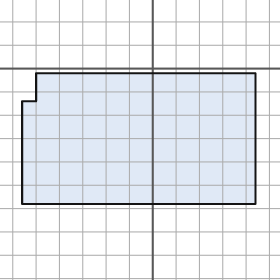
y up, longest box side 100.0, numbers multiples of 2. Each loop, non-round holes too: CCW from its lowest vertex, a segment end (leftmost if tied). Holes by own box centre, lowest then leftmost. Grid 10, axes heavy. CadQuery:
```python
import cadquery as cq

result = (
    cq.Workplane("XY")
    .moveTo(-56.0, -58.0)
    .lineTo(44.0, -58.0)
    .lineTo(44.0, -2.0)
    .lineTo(-50.0, -2.0)
    .lineTo(-50.0, -14.0)
    .lineTo(-56.0, -14.0)
    .close()
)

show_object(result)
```